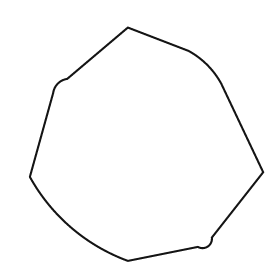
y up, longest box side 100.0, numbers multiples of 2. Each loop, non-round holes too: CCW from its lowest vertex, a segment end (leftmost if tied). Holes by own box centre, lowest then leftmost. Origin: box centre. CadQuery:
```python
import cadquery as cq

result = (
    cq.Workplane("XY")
    .moveTo(-8.0, -50.0)
    .lineTo(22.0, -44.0)
    .threePointArc((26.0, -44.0), (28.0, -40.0))
    .lineTo(50.0, -12.0)
    .lineTo(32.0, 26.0)
    .threePointArc((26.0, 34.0), (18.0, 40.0))
    .lineTo(-8.0, 50.0)
    .lineTo(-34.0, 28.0)
    .threePointArc((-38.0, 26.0), (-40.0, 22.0))
    .lineTo(-50.0, -14.0)
    .threePointArc((-32.0, -36.0), (-8.0, -50.0))
    .close()
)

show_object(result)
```